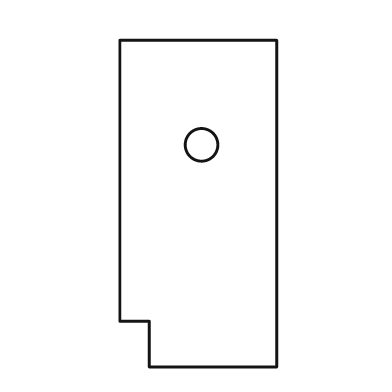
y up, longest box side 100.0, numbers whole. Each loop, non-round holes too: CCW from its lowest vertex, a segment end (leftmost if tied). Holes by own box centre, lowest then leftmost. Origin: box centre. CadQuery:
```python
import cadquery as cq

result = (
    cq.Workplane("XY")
    .moveTo(-15.0, -50.0)
    .lineTo(24.0, -50.0)
    .lineTo(24.0, 50.0)
    .lineTo(-24.0, 50.0)
    .lineTo(-24.0, -36.0)
    .lineTo(-15.0, -36.0)
    .close()
    .moveTo(1.0, 18.0)
    .circle(5.0)
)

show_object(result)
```